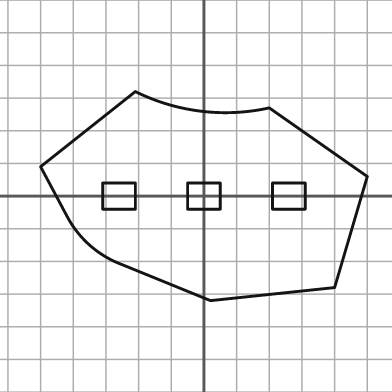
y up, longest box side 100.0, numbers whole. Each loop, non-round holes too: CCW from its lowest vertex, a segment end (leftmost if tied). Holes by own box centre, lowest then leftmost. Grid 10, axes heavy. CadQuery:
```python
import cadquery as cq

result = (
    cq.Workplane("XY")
    .moveTo(2.0, -32.0)
    .lineTo(40.0, -28.0)
    .lineTo(50.0, 6.0)
    .lineTo(20.0, 27.0)
    .threePointArc((-1.0, 26.0), (-21.0, 32.0))
    .lineTo(-50.0, 9.0)
    .lineTo(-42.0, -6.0)
    .threePointArc((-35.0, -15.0), (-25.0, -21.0))
    .close()
    .moveTo(-31.0, -4.0)
    .lineTo(-21.0, -4.0)
    .lineTo(-21.0, 4.0)
    .lineTo(-31.0, 4.0)
    .close()
    .moveTo(-5.0, -4.0)
    .lineTo(5.0, -4.0)
    .lineTo(5.0, 4.0)
    .lineTo(-5.0, 4.0)
    .close()
    .moveTo(21.0, -4.0)
    .lineTo(31.0, -4.0)
    .lineTo(31.0, 4.0)
    .lineTo(21.0, 4.0)
    .close()
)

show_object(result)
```